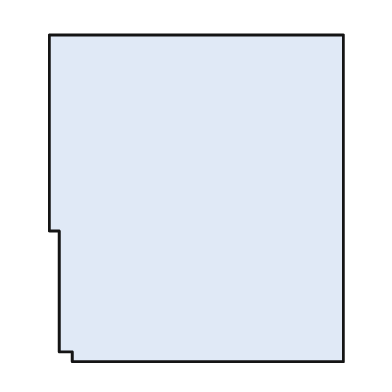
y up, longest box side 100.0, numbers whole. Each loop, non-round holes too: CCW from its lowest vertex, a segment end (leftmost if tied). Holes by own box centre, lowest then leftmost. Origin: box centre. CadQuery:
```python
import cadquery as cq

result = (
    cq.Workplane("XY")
    .moveTo(-38.0, -50.0)
    .lineTo(45.0, -50.0)
    .lineTo(45.0, 50.0)
    .lineTo(-45.0, 50.0)
    .lineTo(-45.0, -10.0)
    .lineTo(-42.0, -10.0)
    .lineTo(-42.0, -47.0)
    .lineTo(-38.0, -47.0)
    .close()
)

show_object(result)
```